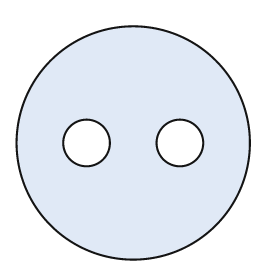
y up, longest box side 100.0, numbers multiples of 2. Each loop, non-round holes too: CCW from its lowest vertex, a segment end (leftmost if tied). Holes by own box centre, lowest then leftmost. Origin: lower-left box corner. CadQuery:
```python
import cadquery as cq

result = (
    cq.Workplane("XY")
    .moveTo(50.0, 50.0)
    .circle(50.0)
    .moveTo(30.0, 50.0)
    .circle(10.0)
    .moveTo(70.0, 50.0)
    .circle(10.0)
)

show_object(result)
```